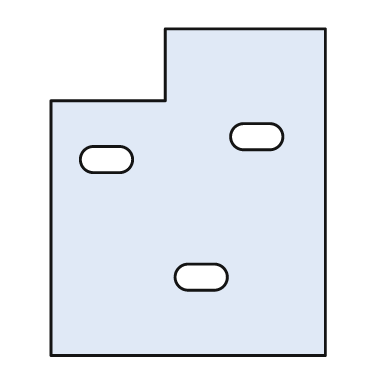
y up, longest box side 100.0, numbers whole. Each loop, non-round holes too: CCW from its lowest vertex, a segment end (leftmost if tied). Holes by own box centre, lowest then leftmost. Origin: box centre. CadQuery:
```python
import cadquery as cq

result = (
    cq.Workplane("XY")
    .moveTo(-42.0, -50.0)
    .lineTo(42.0, -50.0)
    .lineTo(42.0, 50.0)
    .lineTo(-7.0, 50.0)
    .lineTo(-7.0, 28.0)
    .lineTo(-42.0, 28.0)
    .close()
    .moveTo(0.0, -30.0)
    .lineTo(8.0, -30.0)
    .threePointArc((12.0, -26.0), (8.0, -22.0))
    .lineTo(0.0, -22.0)
    .threePointArc((-4.0, -26.0), (0.0, -30.0))
    .close()
    .moveTo(-29.0, 6.0)
    .lineTo(-21.0, 6.0)
    .threePointArc((-17.0, 10.0), (-21.0, 14.0))
    .lineTo(-29.0, 14.0)
    .threePointArc((-33.0, 10.0), (-29.0, 6.0))
    .close()
    .moveTo(17.0, 13.0)
    .lineTo(25.0, 13.0)
    .threePointArc((29.0, 17.0), (25.0, 21.0))
    .lineTo(17.0, 21.0)
    .threePointArc((13.0, 17.0), (17.0, 13.0))
    .close()
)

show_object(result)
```